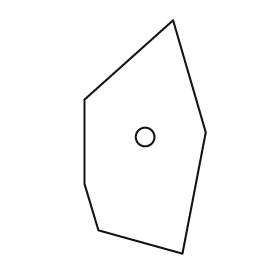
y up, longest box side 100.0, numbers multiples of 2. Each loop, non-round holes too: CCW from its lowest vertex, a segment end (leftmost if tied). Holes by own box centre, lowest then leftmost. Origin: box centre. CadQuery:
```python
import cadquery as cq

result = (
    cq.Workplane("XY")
    .moveTo(16.0, -50.0)
    .lineTo(26.0, 2.0)
    .lineTo(12.0, 50.0)
    .lineTo(-26.0, 16.0)
    .lineTo(-26.0, -20.0)
    .lineTo(-20.0, -40.0)
    .close()
    .moveTo(0.0, 0.0)
    .circle(4.0)
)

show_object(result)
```